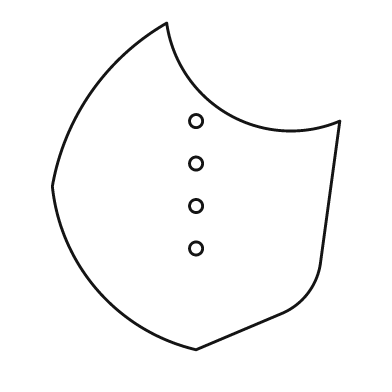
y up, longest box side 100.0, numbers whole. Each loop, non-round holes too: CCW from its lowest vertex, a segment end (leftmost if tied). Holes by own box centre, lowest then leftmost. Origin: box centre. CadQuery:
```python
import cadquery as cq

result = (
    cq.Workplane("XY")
    .moveTo(0.0, -50.0)
    .lineTo(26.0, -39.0)
    .threePointArc((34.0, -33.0), (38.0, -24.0))
    .lineTo(44.0, 20.0)
    .threePointArc((10.0, 22.0), (-9.0, 50.0))
    .threePointArc((-32.0, 29.0), (-44.0, 0.0))
    .threePointArc((-30.0, -32.0), (0.0, -50.0))
    .close()
    .moveTo(0.0, -19.0)
    .circle(2.0)
    .moveTo(0.0, -6.0)
    .circle(2.0)
    .moveTo(0.0, 7.0)
    .circle(2.0)
    .moveTo(0.0, 20.0)
    .circle(2.0)
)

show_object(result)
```